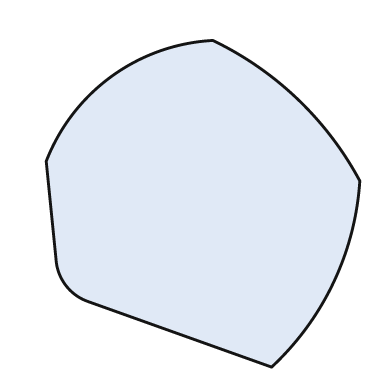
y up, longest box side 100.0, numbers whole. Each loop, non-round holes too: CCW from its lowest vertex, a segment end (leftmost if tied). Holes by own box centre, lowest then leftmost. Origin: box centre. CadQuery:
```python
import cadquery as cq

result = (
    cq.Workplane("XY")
    .moveTo(21.0, -50.0)
    .threePointArc((40.0, -24.0), (48.0, 7.0))
    .threePointArc((29.0, 32.0), (3.0, 50.0))
    .threePointArc((-28.0, 39.0), (-48.0, 13.0))
    .lineTo(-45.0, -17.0)
    .threePointArc((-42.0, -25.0), (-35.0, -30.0))
    .close()
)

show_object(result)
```